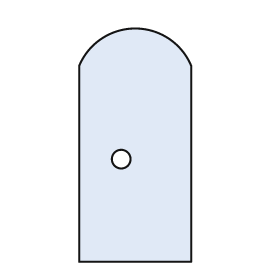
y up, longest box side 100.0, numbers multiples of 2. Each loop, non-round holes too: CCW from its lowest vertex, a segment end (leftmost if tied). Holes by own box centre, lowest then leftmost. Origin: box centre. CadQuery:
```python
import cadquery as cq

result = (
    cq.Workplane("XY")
    .moveTo(-24.0, -50.0)
    .lineTo(24.0, -50.0)
    .lineTo(24.0, 34.0)
    .threePointArc((0.0, 50.0), (-24.0, 34.0))
    .close()
    .moveTo(-6.0, -6.0)
    .circle(4.0)
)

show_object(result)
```